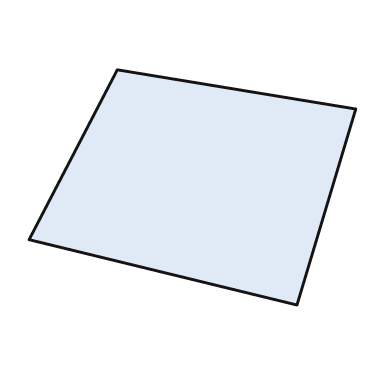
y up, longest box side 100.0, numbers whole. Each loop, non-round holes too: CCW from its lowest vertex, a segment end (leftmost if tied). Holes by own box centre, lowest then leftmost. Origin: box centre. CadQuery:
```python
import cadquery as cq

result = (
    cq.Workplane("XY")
    .moveTo(32.0, -36.0)
    .lineTo(50.0, 24.0)
    .lineTo(-23.0, 36.0)
    .lineTo(-50.0, -16.0)
    .close()
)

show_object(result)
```